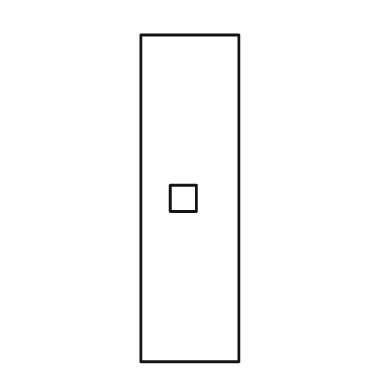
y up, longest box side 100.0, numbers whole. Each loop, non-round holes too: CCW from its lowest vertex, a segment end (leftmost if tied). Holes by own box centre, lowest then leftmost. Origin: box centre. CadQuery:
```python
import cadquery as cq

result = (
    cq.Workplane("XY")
    .moveTo(-15.0, -50.0)
    .lineTo(15.0, -50.0)
    .lineTo(15.0, 50.0)
    .lineTo(-15.0, 50.0)
    .close()
    .moveTo(-6.0, -4.0)
    .lineTo(2.0, -4.0)
    .lineTo(2.0, 4.0)
    .lineTo(-6.0, 4.0)
    .close()
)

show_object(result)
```